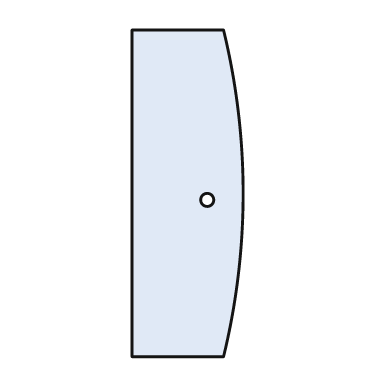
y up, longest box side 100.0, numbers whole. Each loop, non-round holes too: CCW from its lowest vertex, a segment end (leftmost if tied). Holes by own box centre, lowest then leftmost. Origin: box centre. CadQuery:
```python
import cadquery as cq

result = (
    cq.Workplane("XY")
    .moveTo(-17.0, -50.0)
    .lineTo(11.0, -50.0)
    .threePointArc((17.0, 0.0), (11.0, 50.0))
    .lineTo(-17.0, 50.0)
    .close()
    .moveTo(6.0, -2.0)
    .circle(2.0)
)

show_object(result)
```